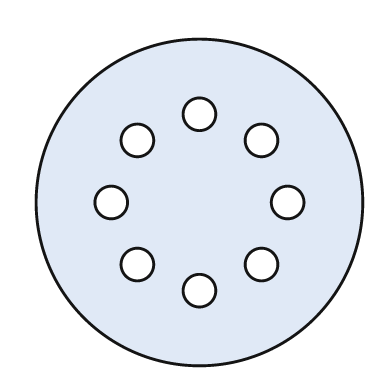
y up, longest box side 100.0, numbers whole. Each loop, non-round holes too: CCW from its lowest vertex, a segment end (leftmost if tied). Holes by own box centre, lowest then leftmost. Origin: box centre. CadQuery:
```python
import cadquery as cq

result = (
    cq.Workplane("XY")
    .moveTo(0.0, 0.0)
    .circle(50.0)
    .moveTo(0.0, -27.0)
    .circle(5.0)
    .moveTo(-19.0, -19.0)
    .circle(5.0)
    .moveTo(19.0, -19.0)
    .circle(5.0)
    .moveTo(-27.0, 0.0)
    .circle(5.0)
    .moveTo(27.0, 0.0)
    .circle(5.0)
    .moveTo(-19.0, 19.0)
    .circle(5.0)
    .moveTo(19.0, 19.0)
    .circle(5.0)
    .moveTo(0.0, 27.0)
    .circle(5.0)
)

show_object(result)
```